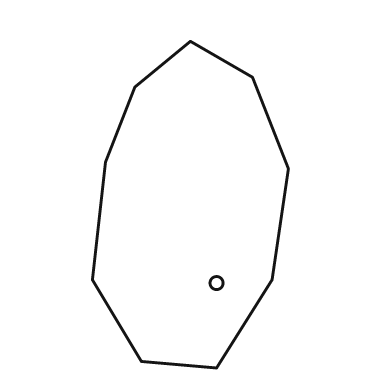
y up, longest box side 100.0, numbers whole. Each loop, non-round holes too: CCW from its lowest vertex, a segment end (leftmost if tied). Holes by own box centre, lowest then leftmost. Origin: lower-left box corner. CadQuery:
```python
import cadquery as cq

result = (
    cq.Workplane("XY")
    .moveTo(38.0, 0.0)
    .lineTo(55.0, 27.0)
    .lineTo(60.0, 61.0)
    .lineTo(49.0, 89.0)
    .lineTo(30.0, 100.0)
    .lineTo(13.0, 86.0)
    .lineTo(4.0, 63.0)
    .lineTo(0.0, 27.0)
    .lineTo(15.0, 2.0)
    .close()
    .moveTo(38.0, 26.0)
    .circle(2.0)
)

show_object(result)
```